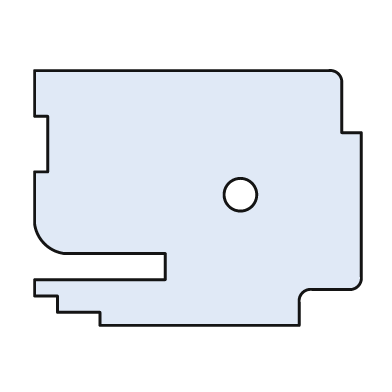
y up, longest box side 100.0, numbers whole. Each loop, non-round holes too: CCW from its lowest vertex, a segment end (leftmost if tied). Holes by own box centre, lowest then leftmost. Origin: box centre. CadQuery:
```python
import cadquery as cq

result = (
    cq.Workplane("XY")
    .moveTo(-30.0, -39.0)
    .lineTo(31.0, -39.0)
    .lineTo(31.0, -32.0)
    .threePointArc((32.0, -29.0), (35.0, -28.0))
    .lineTo(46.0, -28.0)
    .threePointArc((49.0, -27.0), (50.0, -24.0))
    .lineTo(50.0, 20.0)
    .lineTo(44.0, 20.0)
    .lineTo(44.0, 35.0)
    .threePointArc((43.0, 38.0), (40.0, 39.0))
    .lineTo(-50.0, 39.0)
    .lineTo(-50.0, 25.0)
    .lineTo(-46.0, 25.0)
    .lineTo(-46.0, 8.0)
    .lineTo(-50.0, 8.0)
    .lineTo(-50.0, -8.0)
    .threePointArc((-47.0, -14.0), (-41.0, -17.0))
    .lineTo(-10.0, -17.0)
    .lineTo(-10.0, -25.0)
    .lineTo(-50.0, -25.0)
    .lineTo(-50.0, -30.0)
    .lineTo(-43.0, -30.0)
    .lineTo(-43.0, -35.0)
    .lineTo(-30.0, -35.0)
    .close()
    .moveTo(13.0, 1.0)
    .circle(5.0)
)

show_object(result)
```